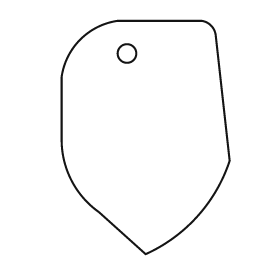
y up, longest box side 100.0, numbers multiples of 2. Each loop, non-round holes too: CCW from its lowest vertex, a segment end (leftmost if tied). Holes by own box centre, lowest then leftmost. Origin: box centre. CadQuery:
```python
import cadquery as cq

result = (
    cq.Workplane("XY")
    .moveTo(0.0, -50.0)
    .threePointArc((22.0, -34.0), (36.0, -10.0))
    .lineTo(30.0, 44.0)
    .threePointArc((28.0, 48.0), (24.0, 50.0))
    .lineTo(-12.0, 50.0)
    .threePointArc((-28.0, 42.0), (-36.0, 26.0))
    .lineTo(-36.0, 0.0)
    .threePointArc((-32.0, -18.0), (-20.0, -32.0))
    .close()
    .moveTo(-8.0, 36.0)
    .circle(4.0)
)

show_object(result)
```